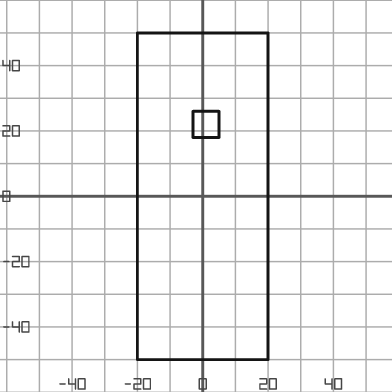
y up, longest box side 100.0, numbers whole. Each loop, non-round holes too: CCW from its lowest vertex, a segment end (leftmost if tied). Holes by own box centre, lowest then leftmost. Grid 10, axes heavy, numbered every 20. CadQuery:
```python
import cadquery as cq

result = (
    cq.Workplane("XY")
    .moveTo(-20.0, -50.0)
    .lineTo(20.0, -50.0)
    .lineTo(20.0, 50.0)
    .lineTo(-20.0, 50.0)
    .close()
    .moveTo(-3.0, 18.0)
    .lineTo(5.0, 18.0)
    .lineTo(5.0, 26.0)
    .lineTo(-3.0, 26.0)
    .close()
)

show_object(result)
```